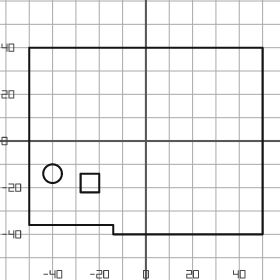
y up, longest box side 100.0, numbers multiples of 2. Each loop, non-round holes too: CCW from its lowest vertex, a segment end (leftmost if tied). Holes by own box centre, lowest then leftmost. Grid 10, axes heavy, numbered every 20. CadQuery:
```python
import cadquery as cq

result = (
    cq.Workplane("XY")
    .moveTo(-14.0, -40.0)
    .lineTo(50.0, -40.0)
    .lineTo(50.0, 40.0)
    .lineTo(-50.0, 40.0)
    .lineTo(-50.0, -36.0)
    .lineTo(-14.0, -36.0)
    .close()
    .moveTo(-28.0, -22.0)
    .lineTo(-20.0, -22.0)
    .lineTo(-20.0, -14.0)
    .lineTo(-28.0, -14.0)
    .close()
    .moveTo(-40.0, -14.0)
    .circle(4.0)
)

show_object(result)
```